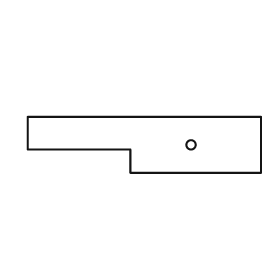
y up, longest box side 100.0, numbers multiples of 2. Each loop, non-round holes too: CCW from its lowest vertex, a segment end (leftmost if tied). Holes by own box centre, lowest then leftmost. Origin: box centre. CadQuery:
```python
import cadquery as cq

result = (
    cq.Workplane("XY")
    .moveTo(-6.0, -12.0)
    .lineTo(50.0, -12.0)
    .lineTo(50.0, 12.0)
    .lineTo(-50.0, 12.0)
    .lineTo(-50.0, -2.0)
    .lineTo(-6.0, -2.0)
    .close()
    .moveTo(20.0, 0.0)
    .circle(2.0)
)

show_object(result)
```